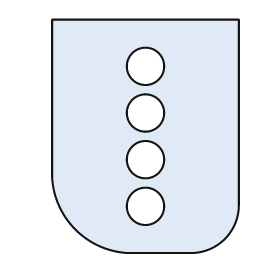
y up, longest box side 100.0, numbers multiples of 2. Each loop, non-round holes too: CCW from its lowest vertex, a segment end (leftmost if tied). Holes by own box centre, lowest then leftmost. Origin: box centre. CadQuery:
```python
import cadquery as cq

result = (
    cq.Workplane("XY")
    .moveTo(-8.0, -50.0)
    .lineTo(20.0, -50.0)
    .threePointArc((34.0, -44.0), (40.0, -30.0))
    .lineTo(40.0, 50.0)
    .lineTo(-40.0, 50.0)
    .lineTo(-40.0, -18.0)
    .threePointArc((-30.0, -40.0), (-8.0, -50.0))
    .close()
    .moveTo(0.0, -30.0)
    .circle(8.0)
    .moveTo(0.0, -10.0)
    .circle(8.0)
    .moveTo(0.0, 10.0)
    .circle(8.0)
    .moveTo(0.0, 30.0)
    .circle(8.0)
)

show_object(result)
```